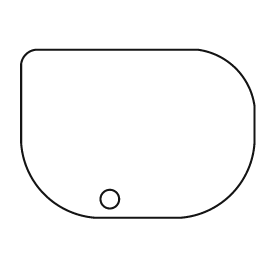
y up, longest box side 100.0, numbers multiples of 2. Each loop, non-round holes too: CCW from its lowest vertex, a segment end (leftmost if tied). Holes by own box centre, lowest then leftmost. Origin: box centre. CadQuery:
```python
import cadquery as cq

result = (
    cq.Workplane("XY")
    .moveTo(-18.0, -36.0)
    .lineTo(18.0, -36.0)
    .threePointArc((40.0, -26.0), (50.0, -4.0))
    .lineTo(50.0, 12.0)
    .threePointArc((42.0, 28.0), (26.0, 36.0))
    .lineTo(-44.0, 36.0)
    .threePointArc((-48.0, 34.0), (-50.0, 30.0))
    .lineTo(-50.0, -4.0)
    .threePointArc((-40.0, -26.0), (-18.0, -36.0))
    .close()
    .moveTo(-12.0, -28.0)
    .circle(4.0)
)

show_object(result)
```